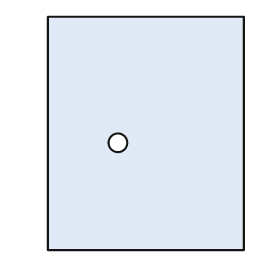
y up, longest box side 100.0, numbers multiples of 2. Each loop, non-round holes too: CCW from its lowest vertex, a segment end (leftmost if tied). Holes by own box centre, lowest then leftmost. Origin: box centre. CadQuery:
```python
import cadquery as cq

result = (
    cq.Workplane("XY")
    .moveTo(-42.0, -50.0)
    .lineTo(42.0, -50.0)
    .lineTo(42.0, 50.0)
    .lineTo(-42.0, 50.0)
    .close()
    .moveTo(-12.0, -4.0)
    .circle(4.0)
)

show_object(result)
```